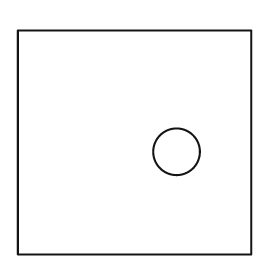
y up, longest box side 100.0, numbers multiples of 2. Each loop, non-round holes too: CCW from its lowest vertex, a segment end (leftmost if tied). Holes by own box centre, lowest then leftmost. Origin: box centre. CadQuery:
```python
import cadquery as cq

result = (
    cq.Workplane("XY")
    .moveTo(-50.0, -48.0)
    .lineTo(50.0, -48.0)
    .lineTo(50.0, 48.0)
    .lineTo(-50.0, 48.0)
    .close()
    .moveTo(18.0, -4.0)
    .circle(10.0)
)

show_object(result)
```